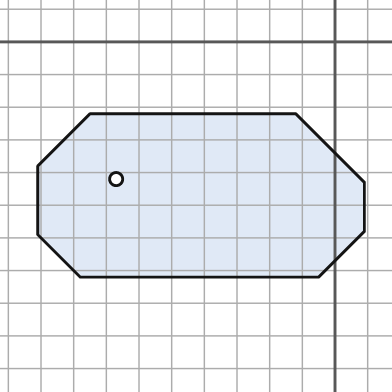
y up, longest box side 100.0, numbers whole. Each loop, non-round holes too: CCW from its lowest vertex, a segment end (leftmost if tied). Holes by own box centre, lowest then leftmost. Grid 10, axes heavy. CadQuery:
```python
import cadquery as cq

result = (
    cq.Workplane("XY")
    .moveTo(-78.0, -72.0)
    .lineTo(-5.0, -72.0)
    .lineTo(9.0, -58.0)
    .lineTo(9.0, -43.0)
    .lineTo(-12.0, -22.0)
    .lineTo(-75.0, -22.0)
    .lineTo(-91.0, -38.0)
    .lineTo(-91.0, -59.0)
    .close()
    .moveTo(-67.0, -42.0)
    .circle(2.0)
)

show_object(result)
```